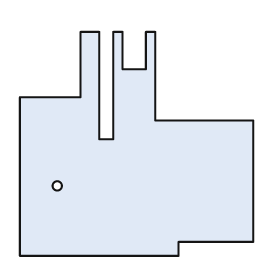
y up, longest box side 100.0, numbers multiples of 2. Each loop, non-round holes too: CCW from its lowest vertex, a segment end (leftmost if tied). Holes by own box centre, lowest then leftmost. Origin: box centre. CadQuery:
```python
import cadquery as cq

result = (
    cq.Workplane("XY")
    .moveTo(-50.0, -48.0)
    .lineTo(18.0, -48.0)
    .lineTo(18.0, -42.0)
    .lineTo(50.0, -42.0)
    .lineTo(50.0, 10.0)
    .lineTo(8.0, 10.0)
    .lineTo(8.0, 48.0)
    .lineTo(4.0, 48.0)
    .lineTo(4.0, 32.0)
    .lineTo(-6.0, 32.0)
    .lineTo(-6.0, 48.0)
    .lineTo(-10.0, 48.0)
    .lineTo(-10.0, 2.0)
    .lineTo(-16.0, 2.0)
    .lineTo(-16.0, 48.0)
    .lineTo(-24.0, 48.0)
    .lineTo(-24.0, 20.0)
    .lineTo(-50.0, 20.0)
    .close()
    .moveTo(-34.0, -18.0)
    .circle(2.0)
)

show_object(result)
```